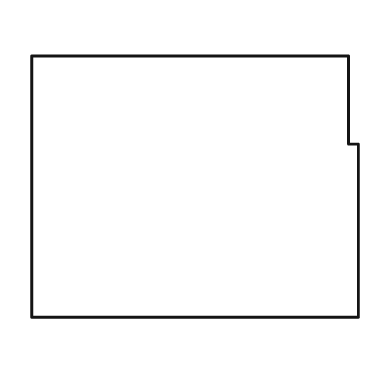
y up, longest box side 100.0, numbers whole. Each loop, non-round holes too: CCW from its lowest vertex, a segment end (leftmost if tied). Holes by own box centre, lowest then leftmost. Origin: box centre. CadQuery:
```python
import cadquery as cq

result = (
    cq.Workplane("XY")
    .moveTo(-50.0, -40.0)
    .lineTo(50.0, -40.0)
    .lineTo(50.0, 13.0)
    .lineTo(47.0, 13.0)
    .lineTo(47.0, 40.0)
    .lineTo(-50.0, 40.0)
    .close()
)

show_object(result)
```